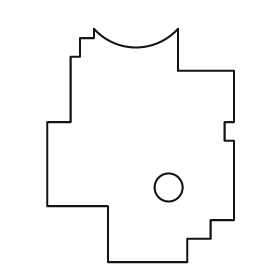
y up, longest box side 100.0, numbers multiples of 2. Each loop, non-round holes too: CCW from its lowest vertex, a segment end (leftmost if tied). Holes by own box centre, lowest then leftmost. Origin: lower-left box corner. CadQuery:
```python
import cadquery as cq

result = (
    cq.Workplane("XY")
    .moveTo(26.0, 0.0)
    .lineTo(60.0, 0.0)
    .lineTo(60.0, 10.0)
    .lineTo(70.0, 10.0)
    .lineTo(70.0, 18.0)
    .lineTo(80.0, 18.0)
    .lineTo(80.0, 52.0)
    .lineTo(76.0, 52.0)
    .lineTo(76.0, 60.0)
    .lineTo(80.0, 60.0)
    .lineTo(80.0, 82.0)
    .lineTo(56.0, 82.0)
    .lineTo(56.0, 100.0)
    .threePointArc((38.0, 92.0), (20.0, 100.0))
    .lineTo(20.0, 96.0)
    .lineTo(14.0, 96.0)
    .lineTo(14.0, 88.0)
    .lineTo(10.0, 88.0)
    .lineTo(10.0, 60.0)
    .lineTo(0.0, 60.0)
    .lineTo(0.0, 24.0)
    .lineTo(26.0, 24.0)
    .close()
    .moveTo(52.0, 32.0)
    .circle(6.0)
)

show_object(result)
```